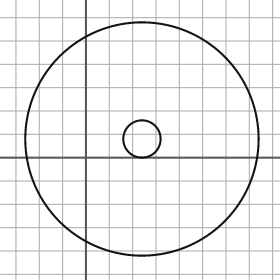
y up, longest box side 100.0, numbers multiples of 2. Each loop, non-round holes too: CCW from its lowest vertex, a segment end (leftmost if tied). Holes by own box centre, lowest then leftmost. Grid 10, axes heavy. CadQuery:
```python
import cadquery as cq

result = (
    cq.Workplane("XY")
    .moveTo(24.0, 8.0)
    .circle(50.0)
    .moveTo(24.0, 8.0)
    .circle(8.0)
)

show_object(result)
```